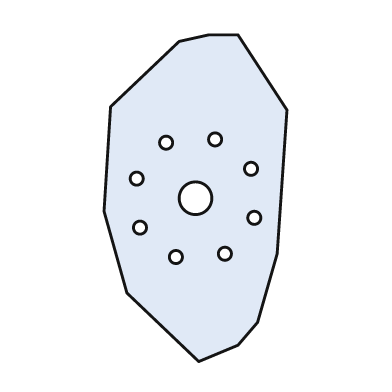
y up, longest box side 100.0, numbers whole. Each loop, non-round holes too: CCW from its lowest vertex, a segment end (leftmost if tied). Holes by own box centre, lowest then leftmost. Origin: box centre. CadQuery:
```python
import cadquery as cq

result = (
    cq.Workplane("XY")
    .moveTo(1.0, -50.0)
    .lineTo(13.0, -45.0)
    .lineTo(19.0, -38.0)
    .lineTo(25.0, -17.0)
    .lineTo(28.0, 27.0)
    .lineTo(13.0, 50.0)
    .lineTo(4.0, 50.0)
    .lineTo(-5.0, 48.0)
    .lineTo(-26.0, 28.0)
    .lineTo(-28.0, -4.0)
    .lineTo(-21.0, -29.0)
    .close()
    .moveTo(-6.0, -18.0)
    .circle(2.0)
    .moveTo(9.0, -17.0)
    .circle(2.0)
    .moveTo(-17.0, -9.0)
    .circle(2.0)
    .moveTo(18.0, -6.0)
    .circle(2.0)
    .moveTo(0.0, 0.0)
    .circle(5.0)
    .moveTo(-18.0, 6.0)
    .circle(2.0)
    .moveTo(17.0, 9.0)
    .circle(2.0)
    .moveTo(-9.0, 17.0)
    .circle(2.0)
    .moveTo(6.0, 18.0)
    .circle(2.0)
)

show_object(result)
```